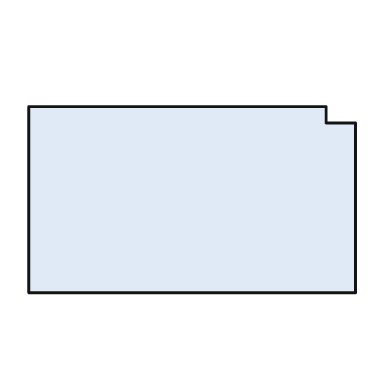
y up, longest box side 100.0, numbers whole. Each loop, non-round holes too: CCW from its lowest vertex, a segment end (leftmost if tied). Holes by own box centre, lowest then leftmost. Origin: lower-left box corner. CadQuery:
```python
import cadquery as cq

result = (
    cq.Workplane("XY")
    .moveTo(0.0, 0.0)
    .lineTo(100.0, 0.0)
    .lineTo(100.0, 52.0)
    .lineTo(91.0, 52.0)
    .lineTo(91.0, 57.0)
    .lineTo(0.0, 57.0)
    .close()
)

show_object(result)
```